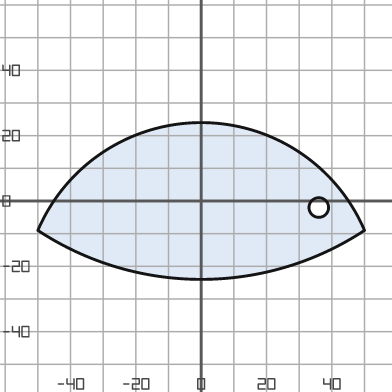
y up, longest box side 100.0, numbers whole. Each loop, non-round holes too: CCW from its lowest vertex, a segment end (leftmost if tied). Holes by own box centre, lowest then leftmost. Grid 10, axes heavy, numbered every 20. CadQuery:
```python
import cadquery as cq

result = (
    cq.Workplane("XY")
    .moveTo(-50.0, -9.0)
    .threePointArc((0.0, -24.0), (50.0, -9.0))
    .threePointArc((0.0, 24.0), (-50.0, -9.0))
    .close()
    .moveTo(36.0, -2.0)
    .circle(3.0)
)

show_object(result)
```